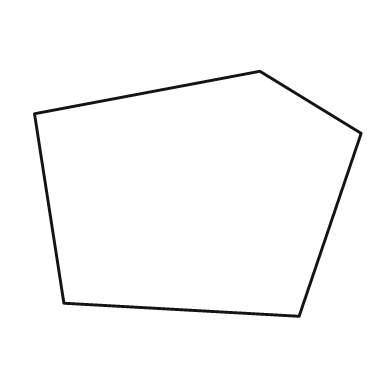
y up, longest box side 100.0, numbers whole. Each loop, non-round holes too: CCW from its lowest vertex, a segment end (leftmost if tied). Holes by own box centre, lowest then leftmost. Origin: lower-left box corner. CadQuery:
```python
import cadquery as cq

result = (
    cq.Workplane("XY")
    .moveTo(81.0, 0.0)
    .lineTo(100.0, 56.0)
    .lineTo(69.0, 75.0)
    .lineTo(0.0, 62.0)
    .lineTo(9.0, 4.0)
    .close()
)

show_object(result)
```